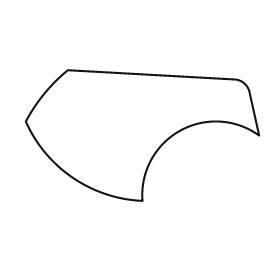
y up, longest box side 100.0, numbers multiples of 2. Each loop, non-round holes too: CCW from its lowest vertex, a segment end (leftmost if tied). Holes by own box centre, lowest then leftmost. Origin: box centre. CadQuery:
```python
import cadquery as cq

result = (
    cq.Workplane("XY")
    .moveTo(0.0, -28.0)
    .threePointArc((16.0, 2.0), (50.0, 0.0))
    .lineTo(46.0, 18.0)
    .threePointArc((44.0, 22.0), (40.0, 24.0))
    .lineTo(-32.0, 28.0)
    .threePointArc((-42.0, 18.0), (-50.0, 6.0))
    .threePointArc((-30.0, -18.0), (0.0, -28.0))
    .close()
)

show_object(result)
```